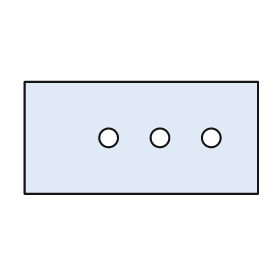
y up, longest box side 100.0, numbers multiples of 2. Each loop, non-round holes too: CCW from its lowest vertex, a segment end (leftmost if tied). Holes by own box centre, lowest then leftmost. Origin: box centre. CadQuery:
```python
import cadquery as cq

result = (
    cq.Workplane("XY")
    .moveTo(-50.0, -24.0)
    .lineTo(50.0, -24.0)
    .lineTo(50.0, 24.0)
    .lineTo(-50.0, 24.0)
    .close()
    .moveTo(-14.0, 0.0)
    .circle(4.0)
    .moveTo(8.0, 0.0)
    .circle(4.0)
    .moveTo(30.0, 0.0)
    .circle(4.0)
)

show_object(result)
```